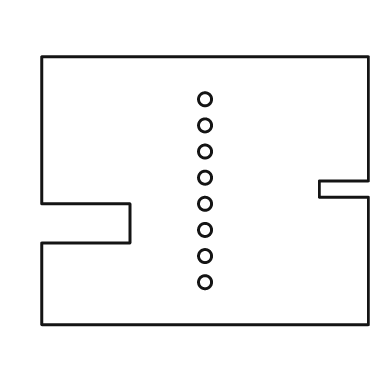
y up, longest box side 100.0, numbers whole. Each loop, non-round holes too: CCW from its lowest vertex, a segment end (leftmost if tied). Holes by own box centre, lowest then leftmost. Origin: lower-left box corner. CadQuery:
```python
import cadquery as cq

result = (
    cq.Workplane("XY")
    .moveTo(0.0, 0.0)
    .lineTo(100.0, 0.0)
    .lineTo(100.0, 39.0)
    .lineTo(85.0, 39.0)
    .lineTo(85.0, 44.0)
    .lineTo(100.0, 44.0)
    .lineTo(100.0, 82.0)
    .lineTo(0.0, 82.0)
    .lineTo(0.0, 37.0)
    .lineTo(27.0, 37.0)
    .lineTo(27.0, 25.0)
    .lineTo(0.0, 25.0)
    .close()
    .moveTo(50.0, 13.0)
    .circle(2.0)
    .moveTo(50.0, 21.0)
    .circle(2.0)
    .moveTo(50.0, 29.0)
    .circle(2.0)
    .moveTo(50.0, 37.0)
    .circle(2.0)
    .moveTo(50.0, 45.0)
    .circle(2.0)
    .moveTo(50.0, 53.0)
    .circle(2.0)
    .moveTo(50.0, 61.0)
    .circle(2.0)
    .moveTo(50.0, 69.0)
    .circle(2.0)
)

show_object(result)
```